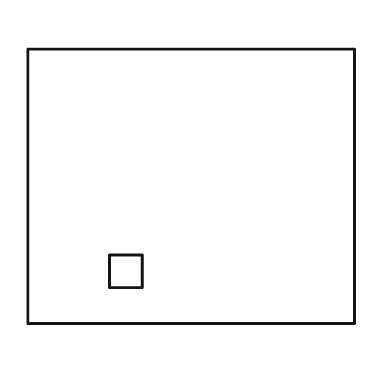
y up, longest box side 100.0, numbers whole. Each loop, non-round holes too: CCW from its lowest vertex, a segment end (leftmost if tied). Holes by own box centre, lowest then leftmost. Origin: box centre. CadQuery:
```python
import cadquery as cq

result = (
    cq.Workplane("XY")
    .moveTo(-50.0, -42.0)
    .lineTo(50.0, -42.0)
    .lineTo(50.0, 42.0)
    .lineTo(-50.0, 42.0)
    .close()
    .moveTo(-25.0, -31.0)
    .lineTo(-15.0, -31.0)
    .lineTo(-15.0, -21.0)
    .lineTo(-25.0, -21.0)
    .close()
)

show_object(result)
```